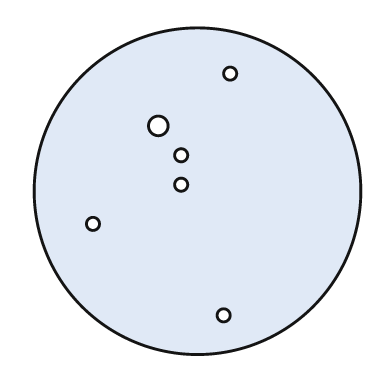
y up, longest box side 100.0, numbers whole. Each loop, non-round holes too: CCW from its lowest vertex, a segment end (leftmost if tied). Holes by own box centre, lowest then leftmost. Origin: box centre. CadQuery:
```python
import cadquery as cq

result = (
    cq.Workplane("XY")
    .moveTo(0.0, 0.0)
    .circle(50.0)
    .moveTo(8.0, -38.0)
    .circle(2.0)
    .moveTo(-32.0, -10.0)
    .circle(2.0)
    .moveTo(-5.0, 2.0)
    .circle(2.0)
    .moveTo(-5.0, 11.0)
    .circle(2.0)
    .moveTo(-12.0, 20.0)
    .circle(3.0)
    .moveTo(10.0, 36.0)
    .circle(2.0)
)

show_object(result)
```